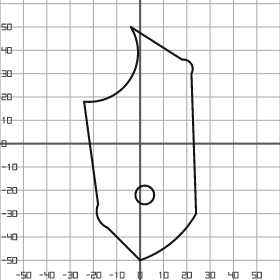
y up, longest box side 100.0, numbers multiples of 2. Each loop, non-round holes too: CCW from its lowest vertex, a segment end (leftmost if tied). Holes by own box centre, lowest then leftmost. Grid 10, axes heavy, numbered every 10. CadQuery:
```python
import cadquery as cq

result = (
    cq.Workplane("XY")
    .moveTo(0.0, -50.0)
    .threePointArc((14.0, -42.0), (24.0, -30.0))
    .lineTo(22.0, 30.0)
    .threePointArc((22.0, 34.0), (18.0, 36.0))
    .lineTo(-4.0, 50.0)
    .threePointArc((-4.0, 28.0), (-24.0, 18.0))
    .lineTo(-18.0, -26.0)
    .threePointArc((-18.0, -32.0), (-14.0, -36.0))
    .close()
    .moveTo(2.0, -22.0)
    .circle(4.0)
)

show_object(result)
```